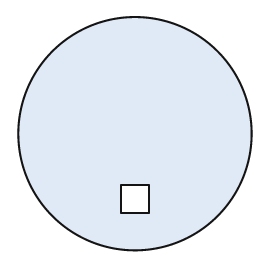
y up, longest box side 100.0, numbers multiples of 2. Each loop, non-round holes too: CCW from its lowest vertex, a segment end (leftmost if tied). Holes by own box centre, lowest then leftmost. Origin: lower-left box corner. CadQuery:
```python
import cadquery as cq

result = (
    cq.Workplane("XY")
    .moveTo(50.0, 50.0)
    .circle(50.0)
    .moveTo(44.0, 16.0)
    .lineTo(56.0, 16.0)
    .lineTo(56.0, 28.0)
    .lineTo(44.0, 28.0)
    .close()
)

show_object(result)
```